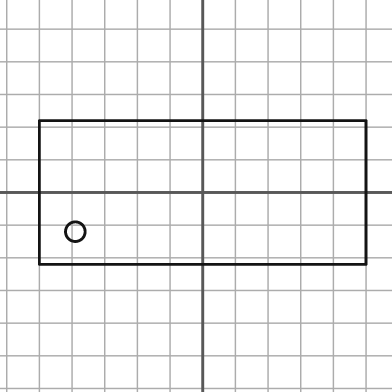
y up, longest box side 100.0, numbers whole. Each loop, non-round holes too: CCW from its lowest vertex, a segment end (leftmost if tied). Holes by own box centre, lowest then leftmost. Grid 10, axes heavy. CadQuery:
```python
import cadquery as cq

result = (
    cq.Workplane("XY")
    .moveTo(-50.0, -22.0)
    .lineTo(50.0, -22.0)
    .lineTo(50.0, 22.0)
    .lineTo(-50.0, 22.0)
    .close()
    .moveTo(-39.0, -12.0)
    .circle(3.0)
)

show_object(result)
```